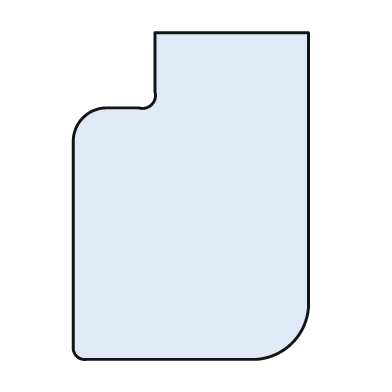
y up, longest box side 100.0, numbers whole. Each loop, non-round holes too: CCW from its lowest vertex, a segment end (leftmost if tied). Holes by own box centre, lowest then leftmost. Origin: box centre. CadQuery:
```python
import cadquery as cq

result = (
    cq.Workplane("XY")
    .moveTo(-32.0, -50.0)
    .lineTo(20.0, -50.0)
    .threePointArc((31.0, -45.0), (36.0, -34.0))
    .lineTo(36.0, 50.0)
    .lineTo(-11.0, 50.0)
    .lineTo(-11.0, 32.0)
    .threePointArc((-12.0, 28.0), (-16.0, 27.0))
    .lineTo(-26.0, 27.0)
    .threePointArc((-33.0, 24.0), (-36.0, 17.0))
    .lineTo(-36.0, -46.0)
    .threePointArc((-35.0, -49.0), (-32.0, -50.0))
    .close()
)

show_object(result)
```